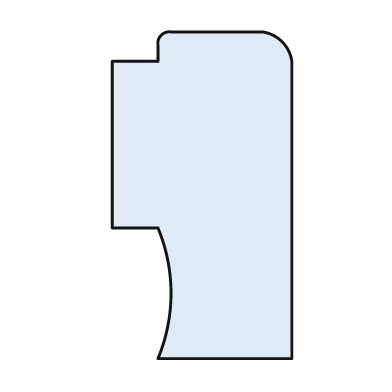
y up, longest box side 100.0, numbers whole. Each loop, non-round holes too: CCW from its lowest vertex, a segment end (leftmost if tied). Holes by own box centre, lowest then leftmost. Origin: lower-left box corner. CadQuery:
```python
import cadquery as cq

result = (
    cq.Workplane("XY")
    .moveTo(14.0, 0.0)
    .lineTo(55.0, 0.0)
    .lineTo(55.0, 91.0)
    .threePointArc((52.0, 97.0), (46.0, 100.0))
    .lineTo(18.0, 100.0)
    .threePointArc((15.0, 99.0), (14.0, 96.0))
    .lineTo(14.0, 91.0)
    .lineTo(0.0, 91.0)
    .lineTo(0.0, 40.0)
    .lineTo(14.0, 40.0)
    .threePointArc((18.0, 20.0), (14.0, 0.0))
    .close()
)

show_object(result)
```